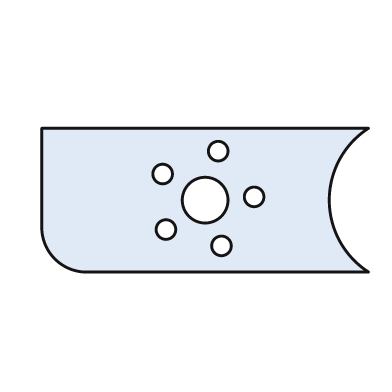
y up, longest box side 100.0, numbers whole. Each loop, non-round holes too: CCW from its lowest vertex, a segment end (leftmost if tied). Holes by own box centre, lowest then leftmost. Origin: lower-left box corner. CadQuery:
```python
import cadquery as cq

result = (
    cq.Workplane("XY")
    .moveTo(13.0, 0.0)
    .lineTo(100.0, 0.0)
    .threePointArc((88.0, 22.0), (100.0, 44.0))
    .lineTo(0.0, 44.0)
    .lineTo(0.0, 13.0)
    .threePointArc((4.0, 4.0), (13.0, 0.0))
    .close()
    .moveTo(55.0, 8.0)
    .circle(3.0)
    .moveTo(38.0, 13.0)
    .circle(3.0)
    .moveTo(50.0, 22.0)
    .circle(7.0)
    .moveTo(65.0, 23.0)
    .circle(3.0)
    .moveTo(37.0, 30.0)
    .circle(3.0)
    .moveTo(54.0, 37.0)
    .circle(3.0)
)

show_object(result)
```